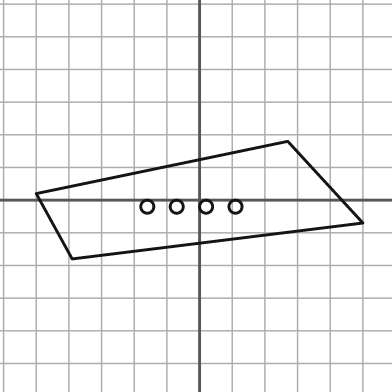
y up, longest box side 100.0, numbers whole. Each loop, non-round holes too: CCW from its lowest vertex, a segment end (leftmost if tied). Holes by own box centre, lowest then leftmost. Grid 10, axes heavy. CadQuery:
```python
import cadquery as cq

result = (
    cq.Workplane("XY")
    .moveTo(-39.0, -18.0)
    .lineTo(50.0, -7.0)
    .lineTo(27.0, 18.0)
    .lineTo(-50.0, 2.0)
    .close()
    .moveTo(-16.0, -2.0)
    .circle(2.0)
    .moveTo(-7.0, -2.0)
    .circle(2.0)
    .moveTo(2.0, -2.0)
    .circle(2.0)
    .moveTo(11.0, -2.0)
    .circle(2.0)
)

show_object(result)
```